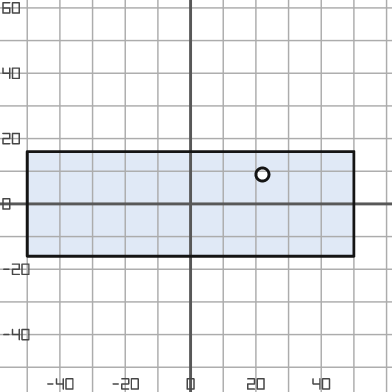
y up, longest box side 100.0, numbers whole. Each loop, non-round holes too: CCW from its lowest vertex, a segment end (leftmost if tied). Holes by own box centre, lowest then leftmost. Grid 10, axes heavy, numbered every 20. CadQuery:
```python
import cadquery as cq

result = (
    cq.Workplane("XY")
    .moveTo(-50.0, -16.0)
    .lineTo(50.0, -16.0)
    .lineTo(50.0, 16.0)
    .lineTo(-50.0, 16.0)
    .close()
    .moveTo(22.0, 9.0)
    .circle(2.0)
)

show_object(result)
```